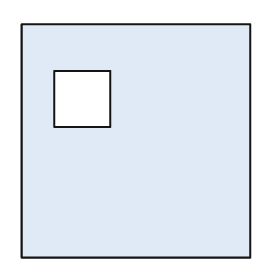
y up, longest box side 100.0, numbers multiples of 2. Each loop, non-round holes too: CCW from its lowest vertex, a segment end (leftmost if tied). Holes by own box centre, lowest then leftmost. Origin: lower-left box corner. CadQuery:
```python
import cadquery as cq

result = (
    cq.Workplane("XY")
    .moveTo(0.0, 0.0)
    .lineTo(98.0, 0.0)
    .lineTo(98.0, 100.0)
    .lineTo(0.0, 100.0)
    .close()
    .moveTo(14.0, 56.0)
    .lineTo(38.0, 56.0)
    .lineTo(38.0, 80.0)
    .lineTo(14.0, 80.0)
    .close()
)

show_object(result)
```